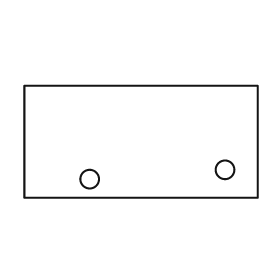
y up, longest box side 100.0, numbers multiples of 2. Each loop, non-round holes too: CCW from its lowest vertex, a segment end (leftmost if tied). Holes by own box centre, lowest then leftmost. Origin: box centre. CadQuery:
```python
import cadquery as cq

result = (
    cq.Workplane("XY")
    .moveTo(-50.0, -24.0)
    .lineTo(50.0, -24.0)
    .lineTo(50.0, 24.0)
    .lineTo(-50.0, 24.0)
    .close()
    .moveTo(-22.0, -16.0)
    .circle(4.0)
    .moveTo(36.0, -12.0)
    .circle(4.0)
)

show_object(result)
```